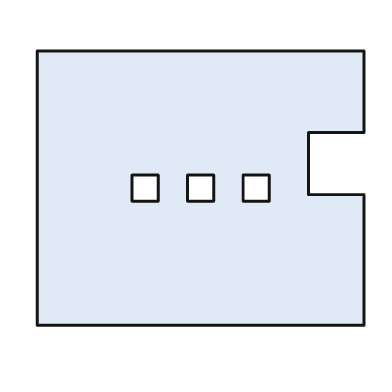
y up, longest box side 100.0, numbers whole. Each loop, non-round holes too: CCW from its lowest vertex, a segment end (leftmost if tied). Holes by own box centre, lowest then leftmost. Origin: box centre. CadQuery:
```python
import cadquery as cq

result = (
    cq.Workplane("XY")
    .moveTo(-50.0, -42.0)
    .lineTo(50.0, -42.0)
    .lineTo(50.0, -2.0)
    .lineTo(33.0, -2.0)
    .lineTo(33.0, 17.0)
    .lineTo(50.0, 17.0)
    .lineTo(50.0, 42.0)
    .lineTo(-50.0, 42.0)
    .close()
    .moveTo(-21.0, -4.0)
    .lineTo(-13.0, -4.0)
    .lineTo(-13.0, 4.0)
    .lineTo(-21.0, 4.0)
    .close()
    .moveTo(-4.0, -4.0)
    .lineTo(4.0, -4.0)
    .lineTo(4.0, 4.0)
    .lineTo(-4.0, 4.0)
    .close()
    .moveTo(13.0, -4.0)
    .lineTo(21.0, -4.0)
    .lineTo(21.0, 4.0)
    .lineTo(13.0, 4.0)
    .close()
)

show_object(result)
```